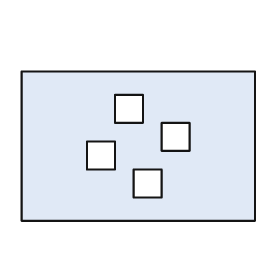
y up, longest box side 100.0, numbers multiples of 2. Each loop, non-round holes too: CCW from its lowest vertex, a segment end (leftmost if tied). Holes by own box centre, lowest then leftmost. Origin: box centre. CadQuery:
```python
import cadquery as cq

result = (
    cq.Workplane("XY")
    .moveTo(-50.0, -32.0)
    .lineTo(50.0, -32.0)
    .lineTo(50.0, 32.0)
    .lineTo(-50.0, 32.0)
    .close()
    .moveTo(-2.0, -22.0)
    .lineTo(10.0, -22.0)
    .lineTo(10.0, -10.0)
    .lineTo(-2.0, -10.0)
    .close()
    .moveTo(-22.0, -10.0)
    .lineTo(-10.0, -10.0)
    .lineTo(-10.0, 2.0)
    .lineTo(-22.0, 2.0)
    .close()
    .moveTo(10.0, -2.0)
    .lineTo(22.0, -2.0)
    .lineTo(22.0, 10.0)
    .lineTo(10.0, 10.0)
    .close()
    .moveTo(-10.0, 10.0)
    .lineTo(2.0, 10.0)
    .lineTo(2.0, 22.0)
    .lineTo(-10.0, 22.0)
    .close()
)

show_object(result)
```